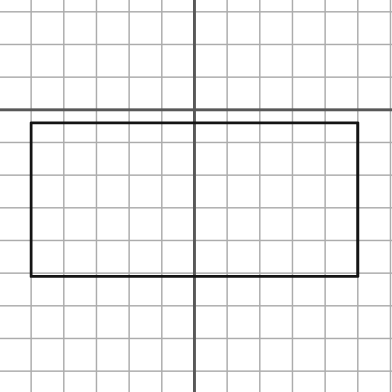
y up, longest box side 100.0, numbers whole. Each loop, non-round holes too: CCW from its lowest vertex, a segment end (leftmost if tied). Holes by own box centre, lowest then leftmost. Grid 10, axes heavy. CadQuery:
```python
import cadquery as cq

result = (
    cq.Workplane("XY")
    .moveTo(-50.0, -51.0)
    .lineTo(50.0, -51.0)
    .lineTo(50.0, -4.0)
    .lineTo(-50.0, -4.0)
    .close()
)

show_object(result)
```